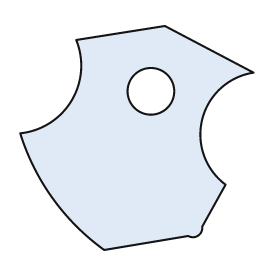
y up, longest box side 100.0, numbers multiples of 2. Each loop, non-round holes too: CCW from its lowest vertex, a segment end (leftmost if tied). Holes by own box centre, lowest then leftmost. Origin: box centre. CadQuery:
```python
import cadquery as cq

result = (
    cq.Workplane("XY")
    .moveTo(-14.0, -48.0)
    .lineTo(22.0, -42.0)
    .threePointArc((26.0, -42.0), (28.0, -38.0))
    .lineTo(38.0, -20.0)
    .threePointArc((28.0, 8.0), (50.0, 28.0))
    .lineTo(12.0, 48.0)
    .lineTo(-26.0, 42.0)
    .threePointArc((-28.0, 16.0), (-50.0, 2.0))
    .threePointArc((-36.0, -26.0), (-14.0, -48.0))
    .close()
    .moveTo(6.0, 20.0)
    .circle(10.0)
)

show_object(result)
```